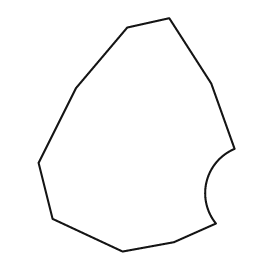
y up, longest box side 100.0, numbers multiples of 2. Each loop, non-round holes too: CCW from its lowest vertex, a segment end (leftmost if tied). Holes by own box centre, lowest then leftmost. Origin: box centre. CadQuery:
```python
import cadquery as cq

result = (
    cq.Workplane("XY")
    .moveTo(-6.0, -50.0)
    .lineTo(16.0, -46.0)
    .lineTo(34.0, -38.0)
    .threePointArc((30.0, -20.0), (42.0, -6.0))
    .lineTo(32.0, 22.0)
    .lineTo(14.0, 50.0)
    .lineTo(-4.0, 46.0)
    .lineTo(-26.0, 20.0)
    .lineTo(-42.0, -12.0)
    .lineTo(-36.0, -36.0)
    .close()
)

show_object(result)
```